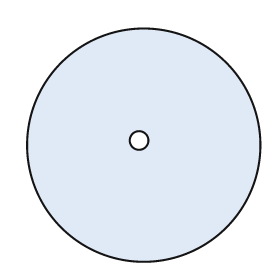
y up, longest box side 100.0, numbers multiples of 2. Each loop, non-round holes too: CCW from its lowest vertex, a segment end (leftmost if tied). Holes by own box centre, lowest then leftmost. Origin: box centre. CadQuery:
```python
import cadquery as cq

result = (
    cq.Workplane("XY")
    .moveTo(0.0, 0.0)
    .circle(50.0)
    .moveTo(-2.0, 2.0)
    .circle(4.0)
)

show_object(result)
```